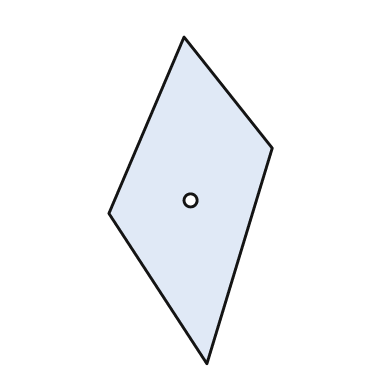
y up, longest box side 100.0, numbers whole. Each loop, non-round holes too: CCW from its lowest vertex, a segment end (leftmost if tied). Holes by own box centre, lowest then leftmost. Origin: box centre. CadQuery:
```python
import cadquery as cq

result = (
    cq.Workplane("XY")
    .moveTo(5.0, -50.0)
    .lineTo(25.0, 16.0)
    .lineTo(-2.0, 50.0)
    .lineTo(-25.0, -4.0)
    .close()
    .moveTo(0.0, 0.0)
    .circle(2.0)
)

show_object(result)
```